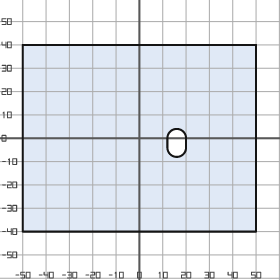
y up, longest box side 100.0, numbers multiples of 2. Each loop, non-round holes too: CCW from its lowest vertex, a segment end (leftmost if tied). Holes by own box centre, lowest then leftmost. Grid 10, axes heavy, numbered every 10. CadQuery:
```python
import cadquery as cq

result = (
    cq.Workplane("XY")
    .moveTo(-50.0, -40.0)
    .lineTo(50.0, -40.0)
    .lineTo(50.0, 40.0)
    .lineTo(-50.0, 40.0)
    .close()
    .moveTo(12.0, -4.0)
    .threePointArc((16.0, -8.0), (20.0, -4.0))
    .lineTo(20.0, 0.0)
    .threePointArc((16.0, 4.0), (12.0, 0.0))
    .close()
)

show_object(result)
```